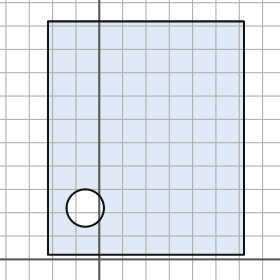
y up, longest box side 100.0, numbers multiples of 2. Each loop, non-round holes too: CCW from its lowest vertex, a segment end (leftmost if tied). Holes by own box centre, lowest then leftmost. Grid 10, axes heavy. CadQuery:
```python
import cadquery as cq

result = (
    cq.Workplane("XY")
    .moveTo(-22.0, 2.0)
    .lineTo(62.0, 2.0)
    .lineTo(62.0, 102.0)
    .lineTo(-22.0, 102.0)
    .close()
    .moveTo(-6.0, 22.0)
    .circle(8.0)
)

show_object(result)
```